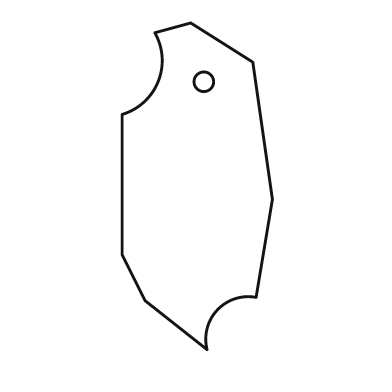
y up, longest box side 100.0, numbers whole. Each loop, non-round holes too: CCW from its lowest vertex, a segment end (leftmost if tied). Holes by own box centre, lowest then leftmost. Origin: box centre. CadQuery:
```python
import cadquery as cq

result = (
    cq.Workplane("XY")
    .moveTo(3.0, -50.0)
    .threePointArc((6.0, -38.0), (18.0, -34.0))
    .lineTo(23.0, -4.0)
    .lineTo(17.0, 38.0)
    .lineTo(-2.0, 50.0)
    .lineTo(-13.0, 47.0)
    .threePointArc((-12.0, 32.0), (-23.0, 22.0))
    .lineTo(-23.0, -21.0)
    .lineTo(-16.0, -35.0)
    .close()
    .moveTo(2.0, 32.0)
    .circle(3.0)
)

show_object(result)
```